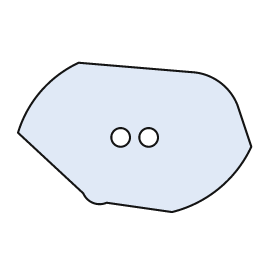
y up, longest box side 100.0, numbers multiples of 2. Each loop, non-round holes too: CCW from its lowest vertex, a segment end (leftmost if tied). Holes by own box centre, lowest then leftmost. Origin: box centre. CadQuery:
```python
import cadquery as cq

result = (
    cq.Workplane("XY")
    .moveTo(16.0, -32.0)
    .threePointArc((36.0, -22.0), (50.0, -4.0))
    .lineTo(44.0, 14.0)
    .threePointArc((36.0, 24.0), (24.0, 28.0))
    .lineTo(-24.0, 32.0)
    .threePointArc((-40.0, 20.0), (-50.0, 2.0))
    .lineTo(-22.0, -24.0)
    .threePointArc((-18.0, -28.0), (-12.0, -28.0))
    .close()
    .moveTo(-6.0, 0.0)
    .circle(4.0)
    .moveTo(6.0, 0.0)
    .circle(4.0)
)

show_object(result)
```